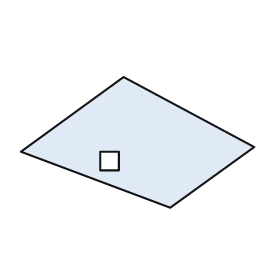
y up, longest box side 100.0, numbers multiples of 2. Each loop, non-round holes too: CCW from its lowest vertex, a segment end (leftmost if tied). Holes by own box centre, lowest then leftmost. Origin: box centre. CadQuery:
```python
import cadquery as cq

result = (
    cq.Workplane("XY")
    .moveTo(14.0, -28.0)
    .lineTo(50.0, -2.0)
    .lineTo(-6.0, 28.0)
    .lineTo(-50.0, -4.0)
    .close()
    .moveTo(-16.0, -12.0)
    .lineTo(-8.0, -12.0)
    .lineTo(-8.0, -4.0)
    .lineTo(-16.0, -4.0)
    .close()
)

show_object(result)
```